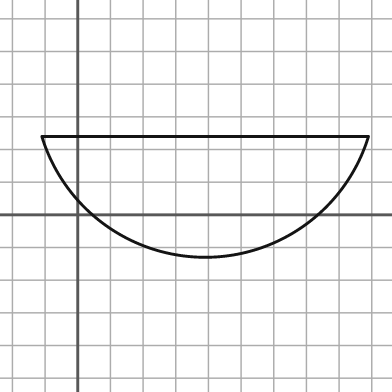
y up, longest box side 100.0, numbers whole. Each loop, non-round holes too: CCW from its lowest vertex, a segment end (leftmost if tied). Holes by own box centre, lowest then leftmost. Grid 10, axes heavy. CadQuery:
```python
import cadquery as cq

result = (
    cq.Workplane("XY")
    .moveTo(-11.0, 24.0)
    .threePointArc((39.0, -13.0), (89.0, 24.0))
    .close()
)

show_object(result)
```